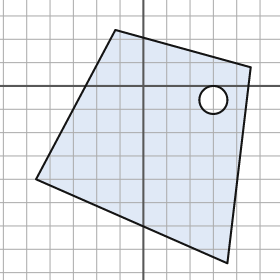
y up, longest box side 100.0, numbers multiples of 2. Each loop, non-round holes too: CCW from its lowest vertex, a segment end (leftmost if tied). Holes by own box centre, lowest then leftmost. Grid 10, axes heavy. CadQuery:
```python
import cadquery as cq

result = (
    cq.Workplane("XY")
    .moveTo(36.0, -76.0)
    .lineTo(46.0, 8.0)
    .lineTo(-12.0, 24.0)
    .lineTo(-46.0, -40.0)
    .close()
    .moveTo(30.0, -6.0)
    .circle(6.0)
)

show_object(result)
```